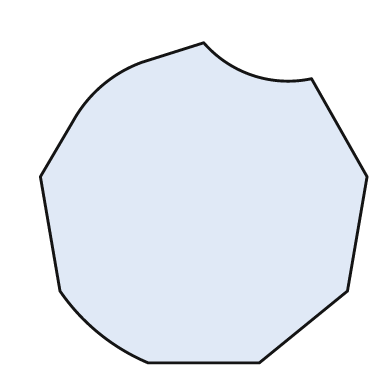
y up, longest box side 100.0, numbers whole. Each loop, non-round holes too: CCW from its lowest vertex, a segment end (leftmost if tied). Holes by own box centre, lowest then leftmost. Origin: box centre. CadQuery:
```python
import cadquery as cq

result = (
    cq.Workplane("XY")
    .moveTo(-17.0, -49.0)
    .lineTo(17.0, -49.0)
    .lineTo(44.0, -27.0)
    .lineTo(50.0, 8.0)
    .lineTo(33.0, 38.0)
    .threePointArc((15.0, 39.0), (0.0, 49.0))
    .lineTo(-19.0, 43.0)
    .threePointArc((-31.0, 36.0), (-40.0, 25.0))
    .lineTo(-50.0, 8.0)
    .lineTo(-44.0, -27.0)
    .threePointArc((-32.0, -40.0), (-17.0, -49.0))
    .close()
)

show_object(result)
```